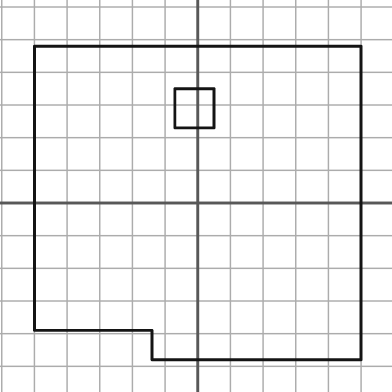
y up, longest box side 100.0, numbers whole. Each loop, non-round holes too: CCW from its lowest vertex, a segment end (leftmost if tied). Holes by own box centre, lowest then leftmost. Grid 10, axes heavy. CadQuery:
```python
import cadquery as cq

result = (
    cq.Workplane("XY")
    .moveTo(-14.0, -48.0)
    .lineTo(50.0, -48.0)
    .lineTo(50.0, 48.0)
    .lineTo(-50.0, 48.0)
    .lineTo(-50.0, -39.0)
    .lineTo(-14.0, -39.0)
    .close()
    .moveTo(-7.0, 23.0)
    .lineTo(5.0, 23.0)
    .lineTo(5.0, 35.0)
    .lineTo(-7.0, 35.0)
    .close()
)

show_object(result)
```